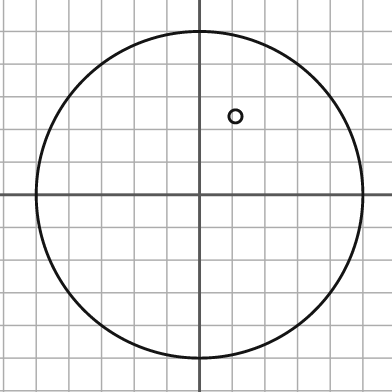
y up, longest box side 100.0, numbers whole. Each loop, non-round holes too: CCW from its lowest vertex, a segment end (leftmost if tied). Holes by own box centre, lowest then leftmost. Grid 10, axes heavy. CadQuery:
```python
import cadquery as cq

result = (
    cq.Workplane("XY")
    .moveTo(0.0, 0.0)
    .circle(50.0)
    .moveTo(11.0, 24.0)
    .circle(2.0)
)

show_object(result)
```